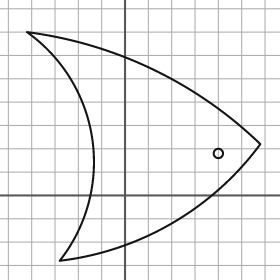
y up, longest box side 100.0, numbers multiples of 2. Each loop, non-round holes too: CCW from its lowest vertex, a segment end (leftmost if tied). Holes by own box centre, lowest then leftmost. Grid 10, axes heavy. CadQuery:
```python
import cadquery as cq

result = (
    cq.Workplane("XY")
    .moveTo(-28.0, -28.0)
    .threePointArc((20.0, -12.0), (58.0, 22.0))
    .threePointArc((12.0, 54.0), (-42.0, 70.0))
    .threePointArc((-14.0, 24.0), (-28.0, -28.0))
    .close()
    .moveTo(40.0, 18.0)
    .circle(2.0)
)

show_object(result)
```